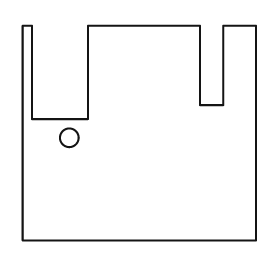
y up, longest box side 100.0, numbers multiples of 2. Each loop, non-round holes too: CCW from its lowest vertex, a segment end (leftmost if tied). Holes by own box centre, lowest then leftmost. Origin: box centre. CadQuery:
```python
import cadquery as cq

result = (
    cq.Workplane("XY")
    .moveTo(-50.0, -46.0)
    .lineTo(50.0, -46.0)
    .lineTo(50.0, 46.0)
    .lineTo(36.0, 46.0)
    .lineTo(36.0, 12.0)
    .lineTo(26.0, 12.0)
    .lineTo(26.0, 46.0)
    .lineTo(-22.0, 46.0)
    .lineTo(-22.0, 6.0)
    .lineTo(-46.0, 6.0)
    .lineTo(-46.0, 46.0)
    .lineTo(-50.0, 46.0)
    .close()
    .moveTo(-30.0, -2.0)
    .circle(4.0)
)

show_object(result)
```